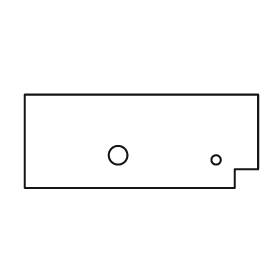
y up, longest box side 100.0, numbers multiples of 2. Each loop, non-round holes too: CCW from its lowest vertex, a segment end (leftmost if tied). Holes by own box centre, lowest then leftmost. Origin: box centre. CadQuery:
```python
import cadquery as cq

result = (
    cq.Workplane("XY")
    .moveTo(-50.0, -20.0)
    .lineTo(40.0, -20.0)
    .lineTo(40.0, -12.0)
    .lineTo(50.0, -12.0)
    .lineTo(50.0, 20.0)
    .lineTo(-50.0, 20.0)
    .close()
    .moveTo(32.0, -8.0)
    .circle(2.0)
    .moveTo(-10.0, -6.0)
    .circle(4.0)
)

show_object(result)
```